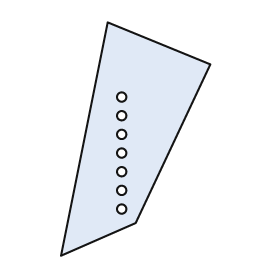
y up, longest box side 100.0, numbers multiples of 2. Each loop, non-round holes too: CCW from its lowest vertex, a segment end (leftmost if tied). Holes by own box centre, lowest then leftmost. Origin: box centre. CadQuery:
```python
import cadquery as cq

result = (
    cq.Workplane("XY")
    .moveTo(-32.0, -50.0)
    .lineTo(0.0, -36.0)
    .lineTo(32.0, 32.0)
    .lineTo(-12.0, 50.0)
    .close()
    .moveTo(-6.0, -30.0)
    .circle(2.0)
    .moveTo(-6.0, -22.0)
    .circle(2.0)
    .moveTo(-6.0, -14.0)
    .circle(2.0)
    .moveTo(-6.0, -6.0)
    .circle(2.0)
    .moveTo(-6.0, 2.0)
    .circle(2.0)
    .moveTo(-6.0, 10.0)
    .circle(2.0)
    .moveTo(-6.0, 18.0)
    .circle(2.0)
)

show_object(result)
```